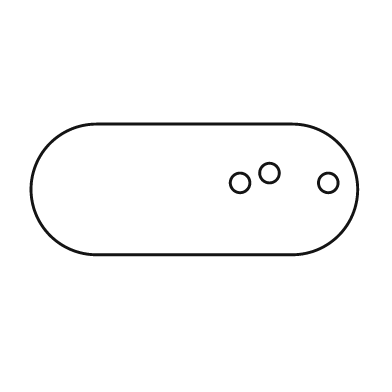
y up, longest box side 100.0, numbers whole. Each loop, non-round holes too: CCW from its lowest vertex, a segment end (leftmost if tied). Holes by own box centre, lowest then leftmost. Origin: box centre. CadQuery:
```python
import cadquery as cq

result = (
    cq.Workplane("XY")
    .moveTo(-30.0, -20.0)
    .lineTo(30.0, -20.0)
    .threePointArc((50.0, 0.0), (30.0, 20.0))
    .lineTo(-30.0, 20.0)
    .threePointArc((-50.0, 0.0), (-30.0, -20.0))
    .close()
    .moveTo(14.0, 2.0)
    .circle(3.0)
    .moveTo(41.0, 2.0)
    .circle(3.0)
    .moveTo(23.0, 5.0)
    .circle(3.0)
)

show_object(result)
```